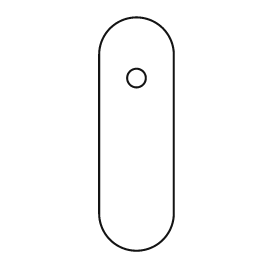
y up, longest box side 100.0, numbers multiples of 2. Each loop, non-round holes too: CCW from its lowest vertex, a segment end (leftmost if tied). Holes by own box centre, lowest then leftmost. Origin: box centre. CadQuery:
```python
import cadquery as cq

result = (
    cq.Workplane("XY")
    .moveTo(-16.0, -34.0)
    .threePointArc((0.0, -50.0), (16.0, -34.0))
    .lineTo(16.0, 34.0)
    .threePointArc((0.0, 50.0), (-16.0, 34.0))
    .close()
    .moveTo(0.0, 24.0)
    .circle(4.0)
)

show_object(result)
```